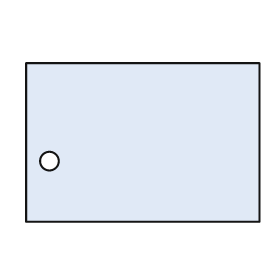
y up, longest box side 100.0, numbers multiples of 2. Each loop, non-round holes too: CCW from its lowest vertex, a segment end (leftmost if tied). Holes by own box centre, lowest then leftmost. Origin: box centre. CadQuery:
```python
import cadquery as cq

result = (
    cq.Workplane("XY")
    .moveTo(-50.0, -34.0)
    .lineTo(50.0, -34.0)
    .lineTo(50.0, 34.0)
    .lineTo(-50.0, 34.0)
    .close()
    .moveTo(-40.0, -8.0)
    .circle(4.0)
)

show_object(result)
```